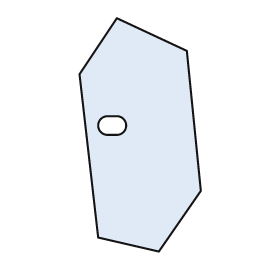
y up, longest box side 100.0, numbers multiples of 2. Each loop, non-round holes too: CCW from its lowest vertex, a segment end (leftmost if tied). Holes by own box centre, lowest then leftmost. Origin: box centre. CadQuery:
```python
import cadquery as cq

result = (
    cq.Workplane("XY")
    .moveTo(8.0, -50.0)
    .lineTo(26.0, -24.0)
    .lineTo(20.0, 36.0)
    .lineTo(-10.0, 50.0)
    .lineTo(-26.0, 26.0)
    .lineTo(-18.0, -44.0)
    .close()
    .moveTo(-14.0, 0.0)
    .lineTo(-10.0, 0.0)
    .threePointArc((-6.0, 4.0), (-10.0, 8.0))
    .lineTo(-14.0, 8.0)
    .threePointArc((-18.0, 4.0), (-14.0, 0.0))
    .close()
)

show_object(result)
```